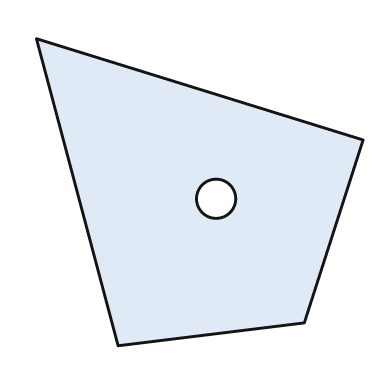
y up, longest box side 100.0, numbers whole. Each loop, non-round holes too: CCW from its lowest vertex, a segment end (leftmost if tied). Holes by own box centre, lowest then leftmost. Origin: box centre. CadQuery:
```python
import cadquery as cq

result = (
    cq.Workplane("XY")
    .moveTo(-25.0, -47.0)
    .lineTo(32.0, -40.0)
    .lineTo(50.0, 16.0)
    .lineTo(-50.0, 47.0)
    .close()
    .moveTo(5.0, -2.0)
    .circle(6.0)
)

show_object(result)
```